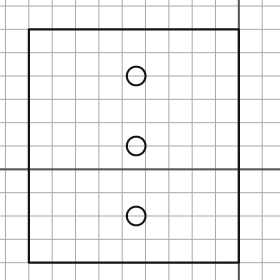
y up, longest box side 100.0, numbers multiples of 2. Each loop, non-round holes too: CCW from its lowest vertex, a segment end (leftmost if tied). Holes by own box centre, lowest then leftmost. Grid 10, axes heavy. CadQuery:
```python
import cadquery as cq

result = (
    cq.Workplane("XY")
    .moveTo(-90.0, -40.0)
    .lineTo(0.0, -40.0)
    .lineTo(0.0, 60.0)
    .lineTo(-90.0, 60.0)
    .close()
    .moveTo(-44.0, -20.0)
    .circle(4.0)
    .moveTo(-44.0, 10.0)
    .circle(4.0)
    .moveTo(-44.0, 40.0)
    .circle(4.0)
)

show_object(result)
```